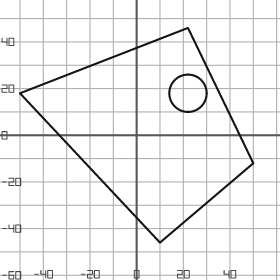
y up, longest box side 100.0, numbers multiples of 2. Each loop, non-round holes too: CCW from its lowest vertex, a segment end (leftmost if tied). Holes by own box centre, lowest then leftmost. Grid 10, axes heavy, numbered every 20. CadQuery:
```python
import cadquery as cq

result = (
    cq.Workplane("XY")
    .moveTo(10.0, -46.0)
    .lineTo(50.0, -12.0)
    .lineTo(22.0, 46.0)
    .lineTo(-50.0, 18.0)
    .close()
    .moveTo(22.0, 18.0)
    .circle(8.0)
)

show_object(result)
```